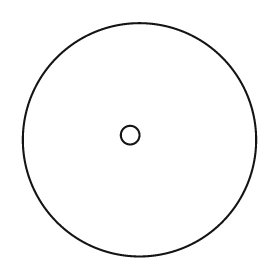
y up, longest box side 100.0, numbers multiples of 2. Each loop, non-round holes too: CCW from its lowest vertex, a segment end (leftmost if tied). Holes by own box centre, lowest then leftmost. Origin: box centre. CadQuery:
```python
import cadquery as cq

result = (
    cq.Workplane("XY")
    .moveTo(0.0, 0.0)
    .circle(50.0)
    .moveTo(-4.0, 2.0)
    .circle(4.0)
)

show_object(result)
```